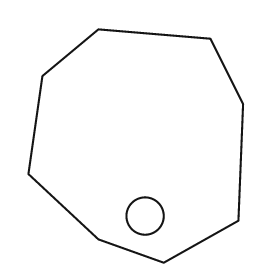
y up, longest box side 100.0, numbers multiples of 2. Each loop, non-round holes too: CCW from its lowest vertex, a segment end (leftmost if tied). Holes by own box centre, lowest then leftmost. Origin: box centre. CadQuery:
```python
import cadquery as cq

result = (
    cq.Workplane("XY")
    .moveTo(12.0, -50.0)
    .lineTo(44.0, -32.0)
    .lineTo(46.0, 18.0)
    .lineTo(32.0, 46.0)
    .lineTo(-16.0, 50.0)
    .lineTo(-40.0, 30.0)
    .lineTo(-46.0, -12.0)
    .lineTo(-16.0, -40.0)
    .close()
    .moveTo(4.0, -30.0)
    .circle(8.0)
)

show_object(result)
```